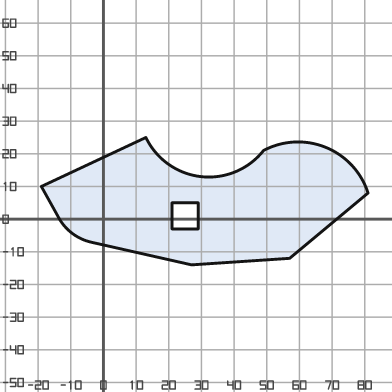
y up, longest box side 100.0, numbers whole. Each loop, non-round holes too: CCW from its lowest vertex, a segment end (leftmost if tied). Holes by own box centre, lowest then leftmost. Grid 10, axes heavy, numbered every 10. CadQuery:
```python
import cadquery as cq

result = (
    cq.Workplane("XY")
    .moveTo(27.0, -14.0)
    .lineTo(57.0, -12.0)
    .lineTo(81.0, 8.0)
    .threePointArc((68.0, 22.0), (49.0, 21.0))
    .threePointArc((30.0, 13.0), (13.0, 25.0))
    .lineTo(-19.0, 10.0)
    .lineTo(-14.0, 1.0)
    .threePointArc((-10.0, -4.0), (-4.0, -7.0))
    .close()
    .moveTo(21.0, -3.0)
    .lineTo(29.0, -3.0)
    .lineTo(29.0, 5.0)
    .lineTo(21.0, 5.0)
    .close()
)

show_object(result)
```